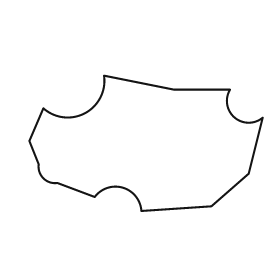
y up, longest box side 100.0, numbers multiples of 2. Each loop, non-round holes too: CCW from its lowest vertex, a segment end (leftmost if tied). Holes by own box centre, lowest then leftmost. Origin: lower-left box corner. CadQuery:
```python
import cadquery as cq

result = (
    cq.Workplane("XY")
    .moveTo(48.0, 0.0)
    .lineTo(78.0, 2.0)
    .lineTo(94.0, 16.0)
    .lineTo(100.0, 40.0)
    .threePointArc((88.0, 40.0), (86.0, 52.0))
    .lineTo(62.0, 52.0)
    .lineTo(32.0, 58.0)
    .threePointArc((24.0, 42.0), (6.0, 44.0))
    .lineTo(0.0, 30.0)
    .lineTo(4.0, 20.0)
    .threePointArc((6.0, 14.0), (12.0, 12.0))
    .lineTo(28.0, 6.0)
    .threePointArc((40.0, 10.0), (48.0, 0.0))
    .close()
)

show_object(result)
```